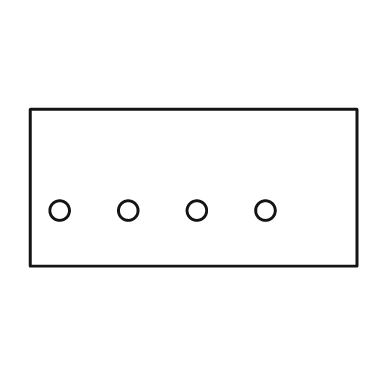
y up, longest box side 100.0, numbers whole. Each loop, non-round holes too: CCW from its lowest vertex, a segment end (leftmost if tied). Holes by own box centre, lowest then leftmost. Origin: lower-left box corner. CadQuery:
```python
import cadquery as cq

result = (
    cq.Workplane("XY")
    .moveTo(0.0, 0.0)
    .lineTo(100.0, 0.0)
    .lineTo(100.0, 48.0)
    .lineTo(0.0, 48.0)
    .close()
    .moveTo(9.0, 17.0)
    .circle(3.0)
    .moveTo(30.0, 17.0)
    .circle(3.0)
    .moveTo(51.0, 17.0)
    .circle(3.0)
    .moveTo(72.0, 17.0)
    .circle(3.0)
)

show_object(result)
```